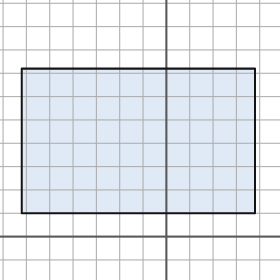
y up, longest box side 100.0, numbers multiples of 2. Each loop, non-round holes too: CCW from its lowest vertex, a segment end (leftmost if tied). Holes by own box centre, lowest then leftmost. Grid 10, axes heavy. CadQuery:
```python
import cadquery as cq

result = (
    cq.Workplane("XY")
    .moveTo(-62.0, 10.0)
    .lineTo(38.0, 10.0)
    .lineTo(38.0, 72.0)
    .lineTo(-62.0, 72.0)
    .close()
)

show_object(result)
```